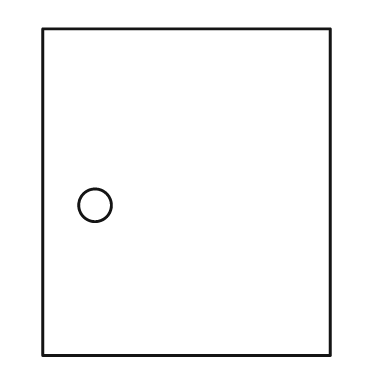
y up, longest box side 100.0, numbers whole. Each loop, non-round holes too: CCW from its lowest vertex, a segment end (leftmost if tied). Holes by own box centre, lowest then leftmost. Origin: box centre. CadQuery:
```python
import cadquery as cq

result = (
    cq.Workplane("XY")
    .moveTo(-44.0, -50.0)
    .lineTo(44.0, -50.0)
    .lineTo(44.0, 50.0)
    .lineTo(-44.0, 50.0)
    .close()
    .moveTo(-28.0, -4.0)
    .circle(5.0)
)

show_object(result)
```